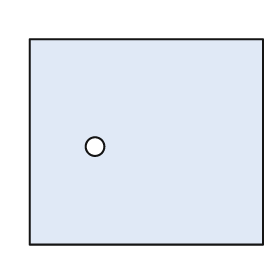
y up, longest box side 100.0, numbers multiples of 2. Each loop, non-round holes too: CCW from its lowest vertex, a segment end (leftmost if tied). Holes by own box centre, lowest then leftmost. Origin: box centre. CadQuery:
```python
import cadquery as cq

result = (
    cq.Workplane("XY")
    .moveTo(-50.0, -44.0)
    .lineTo(50.0, -44.0)
    .lineTo(50.0, 44.0)
    .lineTo(-50.0, 44.0)
    .close()
    .moveTo(-22.0, -2.0)
    .circle(4.0)
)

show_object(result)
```